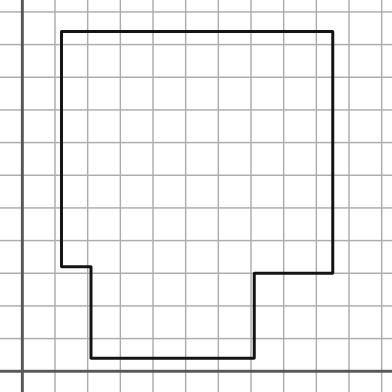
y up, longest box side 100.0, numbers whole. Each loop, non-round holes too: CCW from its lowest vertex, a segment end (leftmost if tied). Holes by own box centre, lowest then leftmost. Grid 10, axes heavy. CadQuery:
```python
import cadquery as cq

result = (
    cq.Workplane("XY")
    .moveTo(21.0, 4.0)
    .lineTo(71.0, 4.0)
    .lineTo(71.0, 30.0)
    .lineTo(95.0, 30.0)
    .lineTo(95.0, 104.0)
    .lineTo(12.0, 104.0)
    .lineTo(12.0, 32.0)
    .lineTo(21.0, 32.0)
    .close()
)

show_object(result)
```